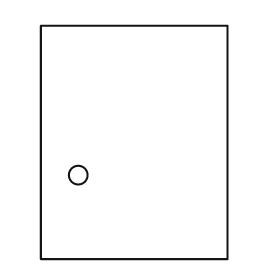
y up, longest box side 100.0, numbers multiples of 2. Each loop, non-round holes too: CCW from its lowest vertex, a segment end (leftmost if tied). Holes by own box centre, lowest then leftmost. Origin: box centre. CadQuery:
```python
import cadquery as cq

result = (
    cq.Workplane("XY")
    .moveTo(-40.0, -50.0)
    .lineTo(40.0, -50.0)
    .lineTo(40.0, 50.0)
    .lineTo(-40.0, 50.0)
    .close()
    .moveTo(-24.0, -14.0)
    .circle(4.0)
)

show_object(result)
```